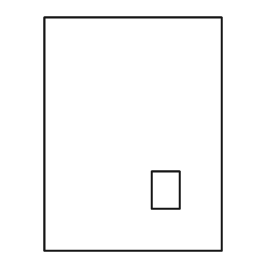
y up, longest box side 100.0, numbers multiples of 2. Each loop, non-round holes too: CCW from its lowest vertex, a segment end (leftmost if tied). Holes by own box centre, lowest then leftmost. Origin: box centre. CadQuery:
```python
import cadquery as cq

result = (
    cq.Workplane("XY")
    .moveTo(-38.0, -50.0)
    .lineTo(38.0, -50.0)
    .lineTo(38.0, 50.0)
    .lineTo(-38.0, 50.0)
    .close()
    .moveTo(8.0, -32.0)
    .lineTo(20.0, -32.0)
    .lineTo(20.0, -16.0)
    .lineTo(8.0, -16.0)
    .close()
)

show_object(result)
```